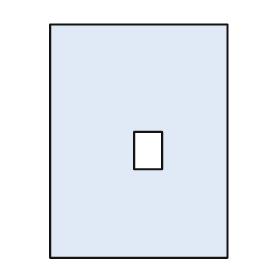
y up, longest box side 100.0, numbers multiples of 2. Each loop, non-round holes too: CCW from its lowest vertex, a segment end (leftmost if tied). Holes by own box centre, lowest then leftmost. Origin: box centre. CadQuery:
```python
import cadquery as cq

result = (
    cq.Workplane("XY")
    .moveTo(-38.0, -50.0)
    .lineTo(38.0, -50.0)
    .lineTo(38.0, 50.0)
    .lineTo(-38.0, 50.0)
    .close()
    .moveTo(-2.0, -12.0)
    .lineTo(10.0, -12.0)
    .lineTo(10.0, 4.0)
    .lineTo(-2.0, 4.0)
    .close()
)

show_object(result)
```